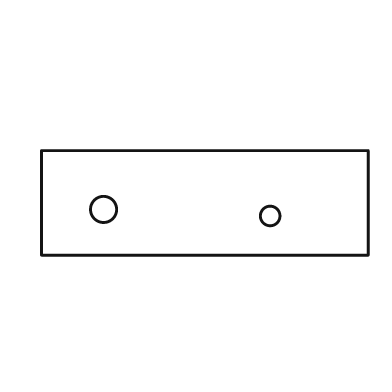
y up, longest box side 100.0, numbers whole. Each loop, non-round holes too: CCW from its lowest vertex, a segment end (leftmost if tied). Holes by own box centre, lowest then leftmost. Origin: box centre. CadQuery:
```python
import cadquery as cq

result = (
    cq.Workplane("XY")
    .moveTo(-50.0, -16.0)
    .lineTo(50.0, -16.0)
    .lineTo(50.0, 16.0)
    .lineTo(-50.0, 16.0)
    .close()
    .moveTo(20.0, -4.0)
    .circle(3.0)
    .moveTo(-31.0, -2.0)
    .circle(4.0)
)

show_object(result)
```